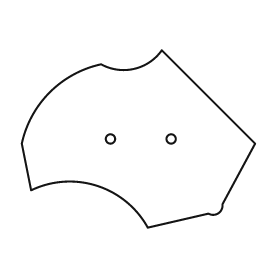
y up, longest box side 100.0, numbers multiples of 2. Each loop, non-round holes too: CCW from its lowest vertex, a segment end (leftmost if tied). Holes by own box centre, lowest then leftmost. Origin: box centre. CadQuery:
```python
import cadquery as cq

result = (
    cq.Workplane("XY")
    .moveTo(4.0, -38.0)
    .lineTo(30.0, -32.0)
    .threePointArc((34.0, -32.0), (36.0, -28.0))
    .lineTo(50.0, -2.0)
    .lineTo(10.0, 38.0)
    .threePointArc((-2.0, 30.0), (-16.0, 32.0))
    .threePointArc((-38.0, 20.0), (-50.0, -2.0))
    .lineTo(-46.0, -22.0)
    .threePointArc((-18.0, -20.0), (4.0, -38.0))
    .close()
    .moveTo(-12.0, 0.0)
    .circle(2.0)
    .moveTo(14.0, 0.0)
    .circle(2.0)
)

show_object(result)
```